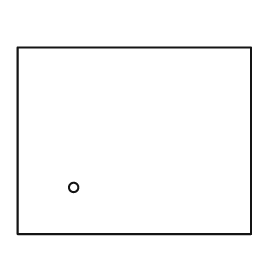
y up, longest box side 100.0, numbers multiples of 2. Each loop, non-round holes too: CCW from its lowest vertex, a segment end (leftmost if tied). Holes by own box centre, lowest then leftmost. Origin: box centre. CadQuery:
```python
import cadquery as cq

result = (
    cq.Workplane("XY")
    .moveTo(-50.0, -40.0)
    .lineTo(50.0, -40.0)
    .lineTo(50.0, 40.0)
    .lineTo(-50.0, 40.0)
    .close()
    .moveTo(-26.0, -20.0)
    .circle(2.0)
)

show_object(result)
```